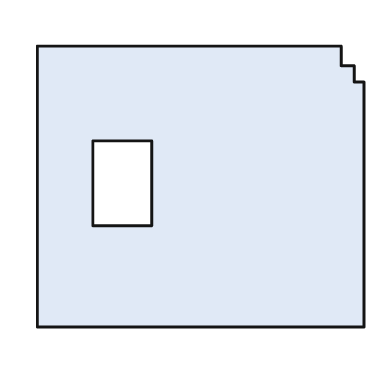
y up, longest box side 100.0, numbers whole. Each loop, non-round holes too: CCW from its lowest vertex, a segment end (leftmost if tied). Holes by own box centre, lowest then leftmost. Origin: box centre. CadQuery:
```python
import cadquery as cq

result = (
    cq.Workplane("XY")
    .moveTo(-50.0, -43.0)
    .lineTo(50.0, -43.0)
    .lineTo(50.0, 32.0)
    .lineTo(47.0, 32.0)
    .lineTo(47.0, 37.0)
    .lineTo(43.0, 37.0)
    .lineTo(43.0, 43.0)
    .lineTo(-50.0, 43.0)
    .close()
    .moveTo(-33.0, -12.0)
    .lineTo(-15.0, -12.0)
    .lineTo(-15.0, 14.0)
    .lineTo(-33.0, 14.0)
    .close()
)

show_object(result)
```